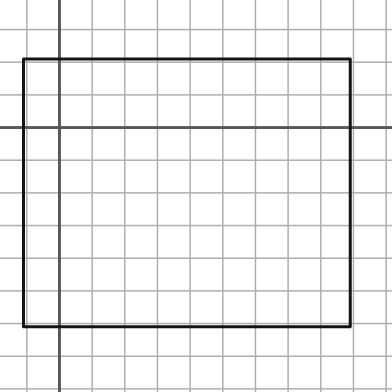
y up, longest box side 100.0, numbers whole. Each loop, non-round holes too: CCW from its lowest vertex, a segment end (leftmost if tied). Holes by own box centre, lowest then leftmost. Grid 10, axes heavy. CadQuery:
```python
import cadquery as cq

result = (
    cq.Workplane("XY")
    .moveTo(-11.0, -61.0)
    .lineTo(89.0, -61.0)
    .lineTo(89.0, 21.0)
    .lineTo(-11.0, 21.0)
    .close()
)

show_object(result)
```